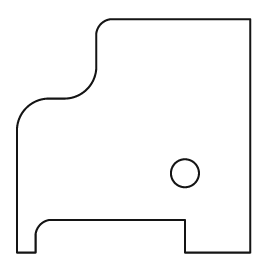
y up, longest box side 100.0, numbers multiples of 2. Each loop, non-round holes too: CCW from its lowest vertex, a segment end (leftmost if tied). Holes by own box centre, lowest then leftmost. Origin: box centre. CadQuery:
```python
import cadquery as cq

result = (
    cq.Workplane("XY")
    .moveTo(-50.0, -50.0)
    .lineTo(-42.0, -50.0)
    .lineTo(-42.0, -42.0)
    .threePointArc((-40.0, -38.0), (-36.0, -36.0))
    .lineTo(22.0, -36.0)
    .lineTo(22.0, -50.0)
    .lineTo(50.0, -50.0)
    .lineTo(50.0, 50.0)
    .lineTo(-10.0, 50.0)
    .threePointArc((-14.0, 48.0), (-16.0, 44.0))
    .lineTo(-16.0, 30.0)
    .threePointArc((-20.0, 20.0), (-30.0, 16.0))
    .lineTo(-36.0, 16.0)
    .threePointArc((-46.0, 12.0), (-50.0, 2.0))
    .close()
    .moveTo(22.0, -16.0)
    .circle(6.0)
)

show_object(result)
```